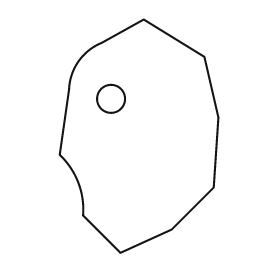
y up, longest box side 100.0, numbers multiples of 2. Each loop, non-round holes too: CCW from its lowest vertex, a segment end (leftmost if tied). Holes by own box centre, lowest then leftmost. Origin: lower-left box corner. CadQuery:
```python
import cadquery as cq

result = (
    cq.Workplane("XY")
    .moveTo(26.0, 0.0)
    .lineTo(48.0, 10.0)
    .lineTo(66.0, 28.0)
    .lineTo(68.0, 58.0)
    .lineTo(62.0, 84.0)
    .lineTo(36.0, 100.0)
    .lineTo(18.0, 90.0)
    .threePointArc((8.0, 82.0), (4.0, 70.0))
    .lineTo(0.0, 42.0)
    .threePointArc((8.0, 30.0), (10.0, 16.0))
    .close()
    .moveTo(22.0, 66.0)
    .circle(6.0)
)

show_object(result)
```